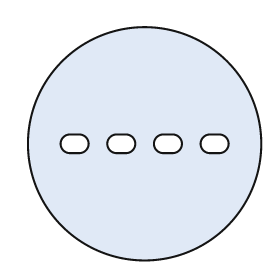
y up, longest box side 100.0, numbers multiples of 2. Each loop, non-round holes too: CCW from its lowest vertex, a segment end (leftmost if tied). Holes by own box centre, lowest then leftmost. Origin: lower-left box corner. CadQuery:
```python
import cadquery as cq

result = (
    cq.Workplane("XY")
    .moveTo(50.0, 50.0)
    .circle(50.0)
    .moveTo(18.0, 46.0)
    .lineTo(22.0, 46.0)
    .threePointArc((26.0, 50.0), (22.0, 54.0))
    .lineTo(18.0, 54.0)
    .threePointArc((14.0, 50.0), (18.0, 46.0))
    .close()
    .moveTo(38.0, 46.0)
    .lineTo(42.0, 46.0)
    .threePointArc((46.0, 50.0), (42.0, 54.0))
    .lineTo(38.0, 54.0)
    .threePointArc((34.0, 50.0), (38.0, 46.0))
    .close()
    .moveTo(58.0, 46.0)
    .lineTo(62.0, 46.0)
    .threePointArc((66.0, 50.0), (62.0, 54.0))
    .lineTo(58.0, 54.0)
    .threePointArc((54.0, 50.0), (58.0, 46.0))
    .close()
    .moveTo(78.0, 46.0)
    .lineTo(82.0, 46.0)
    .threePointArc((86.0, 50.0), (82.0, 54.0))
    .lineTo(78.0, 54.0)
    .threePointArc((74.0, 50.0), (78.0, 46.0))
    .close()
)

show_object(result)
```